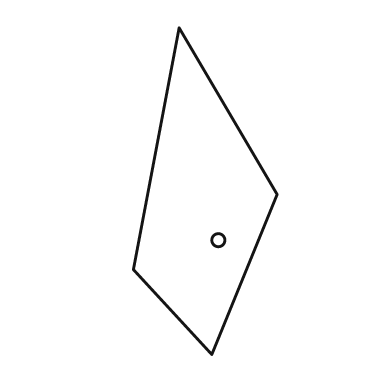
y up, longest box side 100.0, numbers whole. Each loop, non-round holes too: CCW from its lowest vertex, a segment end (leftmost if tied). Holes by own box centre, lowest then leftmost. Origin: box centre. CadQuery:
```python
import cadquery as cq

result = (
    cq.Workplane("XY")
    .moveTo(2.0, -50.0)
    .lineTo(22.0, -1.0)
    .lineTo(-8.0, 50.0)
    .lineTo(-22.0, -24.0)
    .close()
    .moveTo(4.0, -15.0)
    .circle(2.0)
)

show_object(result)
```